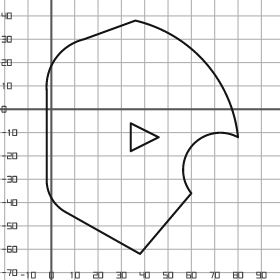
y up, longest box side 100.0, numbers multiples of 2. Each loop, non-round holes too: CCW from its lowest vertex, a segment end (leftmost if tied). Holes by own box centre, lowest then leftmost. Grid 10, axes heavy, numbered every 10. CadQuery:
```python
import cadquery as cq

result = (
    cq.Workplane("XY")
    .moveTo(38.0, -62.0)
    .lineTo(60.0, -36.0)
    .threePointArc((60.0, -16.0), (80.0, -12.0))
    .threePointArc((66.0, 20.0), (36.0, 38.0))
    .lineTo(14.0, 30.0)
    .threePointArc((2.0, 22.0), (-2.0, 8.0))
    .lineTo(-2.0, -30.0)
    .threePointArc((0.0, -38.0), (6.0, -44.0))
    .close()
    .moveTo(34.0, -18.0)
    .lineTo(46.0, -12.0)
    .lineTo(34.0, -6.0)
    .close()
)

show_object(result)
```